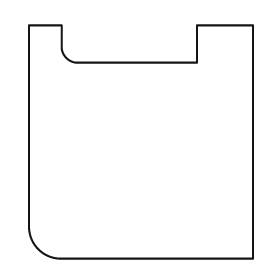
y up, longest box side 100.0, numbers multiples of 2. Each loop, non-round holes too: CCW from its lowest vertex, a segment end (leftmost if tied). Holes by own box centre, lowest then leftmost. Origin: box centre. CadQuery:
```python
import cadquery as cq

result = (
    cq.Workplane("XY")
    .moveTo(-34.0, -50.0)
    .lineTo(48.0, -50.0)
    .lineTo(48.0, 50.0)
    .lineTo(24.0, 50.0)
    .lineTo(24.0, 34.0)
    .lineTo(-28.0, 34.0)
    .threePointArc((-32.0, 36.0), (-34.0, 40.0))
    .lineTo(-34.0, 50.0)
    .lineTo(-48.0, 50.0)
    .lineTo(-48.0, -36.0)
    .threePointArc((-44.0, -46.0), (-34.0, -50.0))
    .close()
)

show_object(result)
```